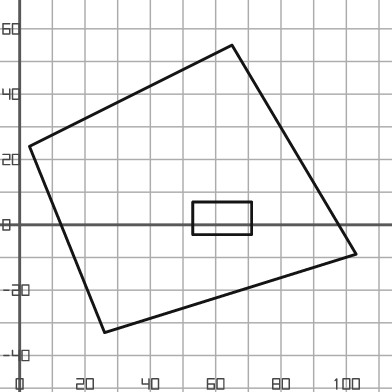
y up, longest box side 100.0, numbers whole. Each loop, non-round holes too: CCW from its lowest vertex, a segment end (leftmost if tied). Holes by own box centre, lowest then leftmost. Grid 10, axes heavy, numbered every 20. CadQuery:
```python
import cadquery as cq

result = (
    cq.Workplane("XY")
    .moveTo(26.0, -33.0)
    .lineTo(103.0, -9.0)
    .lineTo(65.0, 55.0)
    .lineTo(3.0, 24.0)
    .close()
    .moveTo(53.0, -3.0)
    .lineTo(71.0, -3.0)
    .lineTo(71.0, 7.0)
    .lineTo(53.0, 7.0)
    .close()
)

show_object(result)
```